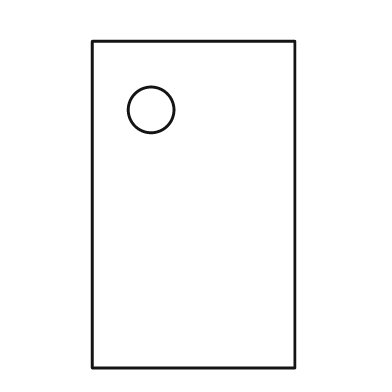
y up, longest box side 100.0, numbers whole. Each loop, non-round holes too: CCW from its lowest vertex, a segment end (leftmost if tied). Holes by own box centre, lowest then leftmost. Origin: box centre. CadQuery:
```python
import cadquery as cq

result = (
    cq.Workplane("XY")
    .moveTo(-31.0, -50.0)
    .lineTo(31.0, -50.0)
    .lineTo(31.0, 50.0)
    .lineTo(-31.0, 50.0)
    .close()
    .moveTo(-13.0, 29.0)
    .circle(7.0)
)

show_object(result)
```